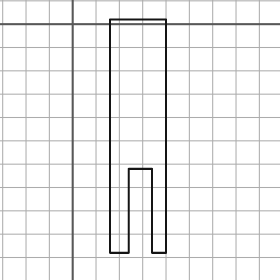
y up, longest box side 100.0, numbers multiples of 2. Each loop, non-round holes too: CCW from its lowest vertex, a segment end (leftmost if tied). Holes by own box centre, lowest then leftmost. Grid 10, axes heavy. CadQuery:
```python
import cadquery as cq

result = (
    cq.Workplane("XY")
    .moveTo(16.0, -98.0)
    .lineTo(24.0, -98.0)
    .lineTo(24.0, -62.0)
    .lineTo(34.0, -62.0)
    .lineTo(34.0, -98.0)
    .lineTo(40.0, -98.0)
    .lineTo(40.0, 2.0)
    .lineTo(16.0, 2.0)
    .close()
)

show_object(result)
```